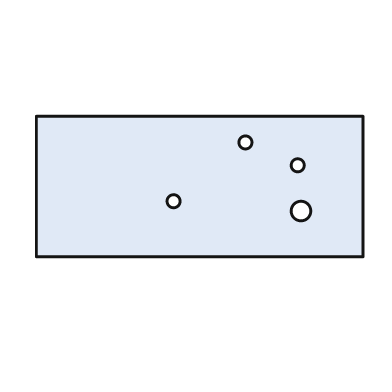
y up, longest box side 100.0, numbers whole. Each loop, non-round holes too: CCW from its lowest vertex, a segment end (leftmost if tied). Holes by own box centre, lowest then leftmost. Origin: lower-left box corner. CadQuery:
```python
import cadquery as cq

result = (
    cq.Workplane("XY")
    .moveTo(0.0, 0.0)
    .lineTo(100.0, 0.0)
    .lineTo(100.0, 43.0)
    .lineTo(0.0, 43.0)
    .close()
    .moveTo(81.0, 14.0)
    .circle(3.0)
    .moveTo(42.0, 17.0)
    .circle(2.0)
    .moveTo(80.0, 28.0)
    .circle(2.0)
    .moveTo(64.0, 35.0)
    .circle(2.0)
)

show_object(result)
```